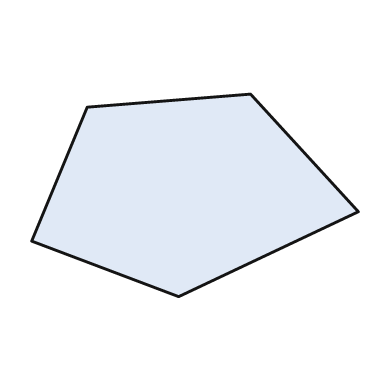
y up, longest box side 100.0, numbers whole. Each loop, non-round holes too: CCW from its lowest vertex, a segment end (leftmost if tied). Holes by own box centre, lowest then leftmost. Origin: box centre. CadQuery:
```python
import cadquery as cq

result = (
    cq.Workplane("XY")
    .moveTo(-5.0, -31.0)
    .lineTo(50.0, -5.0)
    .lineTo(17.0, 31.0)
    .lineTo(-33.0, 27.0)
    .lineTo(-50.0, -14.0)
    .close()
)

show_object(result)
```